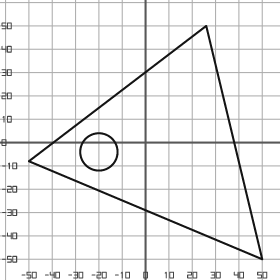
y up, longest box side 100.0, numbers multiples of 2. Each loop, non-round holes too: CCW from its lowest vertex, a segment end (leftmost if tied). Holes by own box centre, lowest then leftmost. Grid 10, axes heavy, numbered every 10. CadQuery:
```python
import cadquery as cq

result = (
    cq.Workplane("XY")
    .moveTo(50.0, -50.0)
    .lineTo(26.0, 50.0)
    .lineTo(-50.0, -8.0)
    .close()
    .moveTo(-20.0, -4.0)
    .circle(8.0)
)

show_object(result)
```